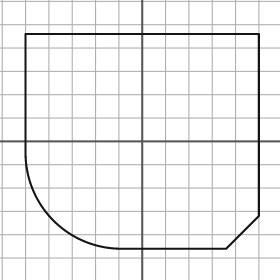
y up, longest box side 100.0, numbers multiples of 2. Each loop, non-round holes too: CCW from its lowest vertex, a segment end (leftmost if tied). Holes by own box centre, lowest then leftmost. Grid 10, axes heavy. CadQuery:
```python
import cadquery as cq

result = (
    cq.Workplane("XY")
    .moveTo(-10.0, -46.0)
    .lineTo(36.0, -46.0)
    .lineTo(50.0, -32.0)
    .lineTo(50.0, 46.0)
    .lineTo(-50.0, 46.0)
    .lineTo(-50.0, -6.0)
    .threePointArc((-38.0, -34.0), (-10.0, -46.0))
    .close()
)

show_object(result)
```